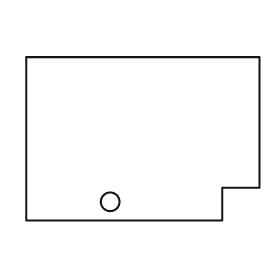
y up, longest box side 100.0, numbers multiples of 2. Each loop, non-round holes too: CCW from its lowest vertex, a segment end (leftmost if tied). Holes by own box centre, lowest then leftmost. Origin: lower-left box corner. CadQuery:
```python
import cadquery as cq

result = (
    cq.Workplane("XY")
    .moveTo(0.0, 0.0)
    .lineTo(84.0, 0.0)
    .lineTo(84.0, 14.0)
    .lineTo(100.0, 14.0)
    .lineTo(100.0, 70.0)
    .lineTo(0.0, 70.0)
    .close()
    .moveTo(36.0, 8.0)
    .circle(4.0)
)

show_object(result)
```